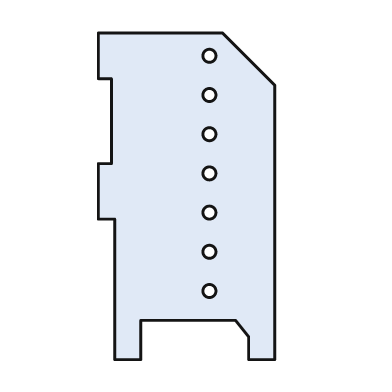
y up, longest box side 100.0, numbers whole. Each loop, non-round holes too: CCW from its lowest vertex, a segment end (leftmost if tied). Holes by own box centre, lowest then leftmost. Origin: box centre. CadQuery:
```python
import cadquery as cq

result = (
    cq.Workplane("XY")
    .moveTo(-22.0, -50.0)
    .lineTo(-14.0, -50.0)
    .lineTo(-14.0, -38.0)
    .lineTo(15.0, -38.0)
    .lineTo(19.0, -43.0)
    .lineTo(19.0, -50.0)
    .lineTo(27.0, -50.0)
    .lineTo(27.0, 34.0)
    .lineTo(11.0, 50.0)
    .lineTo(-27.0, 50.0)
    .lineTo(-27.0, 36.0)
    .lineTo(-23.0, 36.0)
    .lineTo(-23.0, 10.0)
    .lineTo(-27.0, 10.0)
    .lineTo(-27.0, -7.0)
    .lineTo(-22.0, -7.0)
    .close()
    .moveTo(7.0, -29.0)
    .circle(2.0)
    .moveTo(7.0, -17.0)
    .circle(2.0)
    .moveTo(7.0, -5.0)
    .circle(2.0)
    .moveTo(7.0, 7.0)
    .circle(2.0)
    .moveTo(7.0, 19.0)
    .circle(2.0)
    .moveTo(7.0, 31.0)
    .circle(2.0)
    .moveTo(7.0, 43.0)
    .circle(2.0)
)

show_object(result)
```